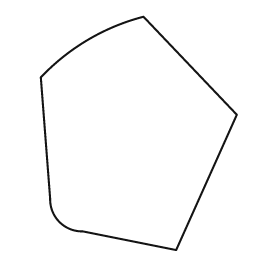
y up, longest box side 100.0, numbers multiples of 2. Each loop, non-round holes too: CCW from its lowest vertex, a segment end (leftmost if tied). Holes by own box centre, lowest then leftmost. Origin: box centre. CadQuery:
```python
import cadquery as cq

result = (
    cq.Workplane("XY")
    .moveTo(16.0, -50.0)
    .lineTo(42.0, 8.0)
    .lineTo(2.0, 50.0)
    .threePointArc((-22.0, 40.0), (-42.0, 24.0))
    .lineTo(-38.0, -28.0)
    .threePointArc((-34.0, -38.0), (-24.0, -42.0))
    .close()
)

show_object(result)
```